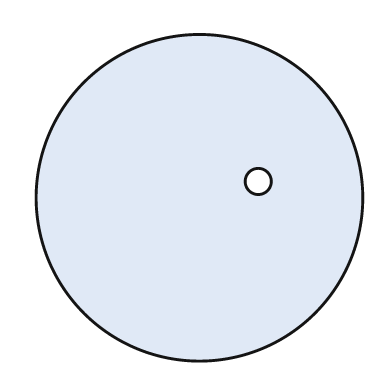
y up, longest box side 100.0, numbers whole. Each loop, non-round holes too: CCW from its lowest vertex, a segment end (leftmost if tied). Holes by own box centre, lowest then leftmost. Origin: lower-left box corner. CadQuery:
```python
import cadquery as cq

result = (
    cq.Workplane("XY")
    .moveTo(50.0, 50.0)
    .circle(50.0)
    .moveTo(68.0, 55.0)
    .circle(4.0)
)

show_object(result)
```